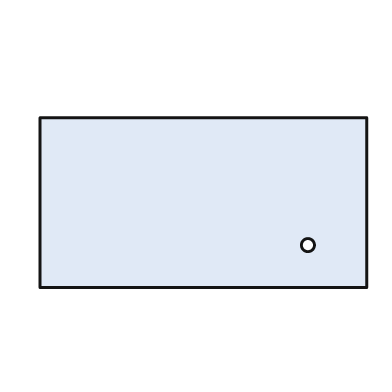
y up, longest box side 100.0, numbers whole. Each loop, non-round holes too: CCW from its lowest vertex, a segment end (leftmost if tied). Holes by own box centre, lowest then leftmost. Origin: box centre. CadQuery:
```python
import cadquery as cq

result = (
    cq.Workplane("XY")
    .moveTo(-50.0, -26.0)
    .lineTo(50.0, -26.0)
    .lineTo(50.0, 26.0)
    .lineTo(-50.0, 26.0)
    .close()
    .moveTo(32.0, -13.0)
    .circle(2.0)
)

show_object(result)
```